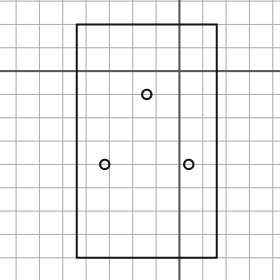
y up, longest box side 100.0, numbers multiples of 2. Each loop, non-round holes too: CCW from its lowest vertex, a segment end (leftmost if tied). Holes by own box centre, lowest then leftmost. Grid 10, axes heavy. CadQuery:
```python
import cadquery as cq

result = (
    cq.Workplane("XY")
    .moveTo(-44.0, -80.0)
    .lineTo(16.0, -80.0)
    .lineTo(16.0, 20.0)
    .lineTo(-44.0, 20.0)
    .close()
    .moveTo(-32.0, -40.0)
    .circle(2.0)
    .moveTo(4.0, -40.0)
    .circle(2.0)
    .moveTo(-14.0, -10.0)
    .circle(2.0)
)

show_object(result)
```